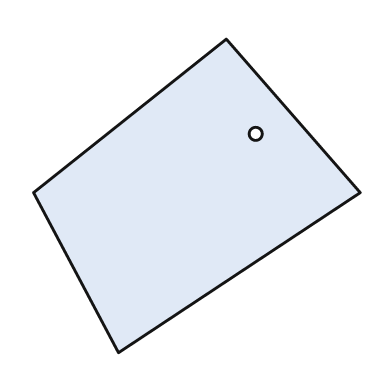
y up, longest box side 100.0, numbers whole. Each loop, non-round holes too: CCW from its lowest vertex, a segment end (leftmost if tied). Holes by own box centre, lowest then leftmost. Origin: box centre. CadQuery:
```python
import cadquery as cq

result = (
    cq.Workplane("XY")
    .moveTo(-24.0, -48.0)
    .lineTo(50.0, 1.0)
    .lineTo(9.0, 48.0)
    .lineTo(-50.0, 1.0)
    .close()
    .moveTo(18.0, 19.0)
    .circle(2.0)
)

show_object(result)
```